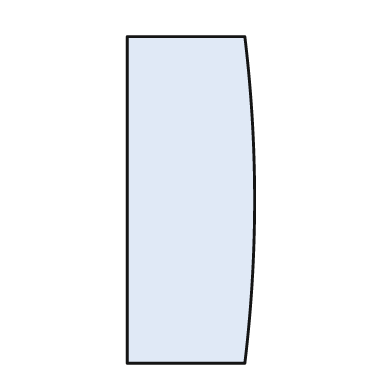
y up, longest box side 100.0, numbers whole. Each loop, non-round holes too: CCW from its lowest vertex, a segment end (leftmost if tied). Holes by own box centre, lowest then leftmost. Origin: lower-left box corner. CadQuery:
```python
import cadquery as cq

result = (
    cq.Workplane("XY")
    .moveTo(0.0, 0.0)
    .lineTo(36.0, 0.0)
    .threePointArc((39.0, 50.0), (36.0, 100.0))
    .lineTo(0.0, 100.0)
    .close()
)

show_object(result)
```